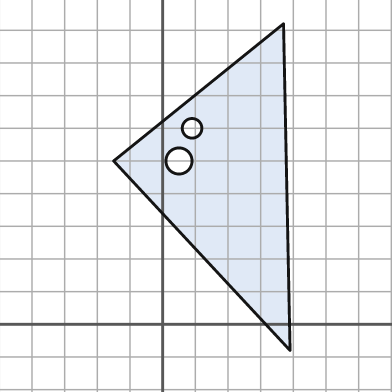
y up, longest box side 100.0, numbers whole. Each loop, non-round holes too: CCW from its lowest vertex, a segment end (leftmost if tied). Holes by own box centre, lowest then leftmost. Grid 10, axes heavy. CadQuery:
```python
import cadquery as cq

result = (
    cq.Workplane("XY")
    .moveTo(39.0, -8.0)
    .lineTo(37.0, 92.0)
    .lineTo(-15.0, 50.0)
    .close()
    .moveTo(5.0, 50.0)
    .circle(4.0)
    .moveTo(9.0, 60.0)
    .circle(3.0)
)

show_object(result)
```